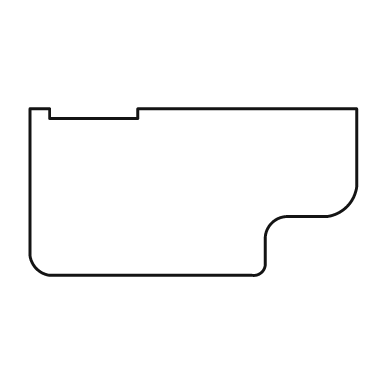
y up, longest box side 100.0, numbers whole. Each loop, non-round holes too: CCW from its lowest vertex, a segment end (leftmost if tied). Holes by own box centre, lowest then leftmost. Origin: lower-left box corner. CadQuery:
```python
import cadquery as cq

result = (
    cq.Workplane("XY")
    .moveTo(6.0, 0.0)
    .lineTo(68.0, 0.0)
    .threePointArc((71.0, 1.0), (72.0, 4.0))
    .lineTo(72.0, 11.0)
    .threePointArc((74.0, 16.0), (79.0, 18.0))
    .lineTo(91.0, 18.0)
    .threePointArc((97.0, 21.0), (100.0, 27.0))
    .lineTo(100.0, 51.0)
    .lineTo(33.0, 51.0)
    .lineTo(33.0, 48.0)
    .lineTo(6.0, 48.0)
    .lineTo(6.0, 51.0)
    .lineTo(0.0, 51.0)
    .lineTo(0.0, 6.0)
    .threePointArc((2.0, 2.0), (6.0, 0.0))
    .close()
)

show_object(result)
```